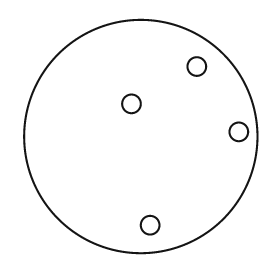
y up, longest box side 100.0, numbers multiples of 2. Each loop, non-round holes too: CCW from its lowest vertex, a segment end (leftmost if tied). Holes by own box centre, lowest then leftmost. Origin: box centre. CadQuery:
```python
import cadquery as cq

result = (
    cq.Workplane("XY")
    .moveTo(0.0, 0.0)
    .circle(50.0)
    .moveTo(4.0, -38.0)
    .circle(4.0)
    .moveTo(42.0, 2.0)
    .circle(4.0)
    .moveTo(-4.0, 14.0)
    .circle(4.0)
    .moveTo(24.0, 30.0)
    .circle(4.0)
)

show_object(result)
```